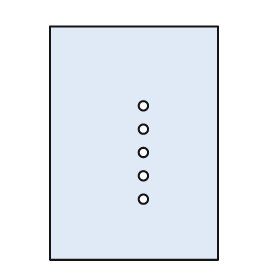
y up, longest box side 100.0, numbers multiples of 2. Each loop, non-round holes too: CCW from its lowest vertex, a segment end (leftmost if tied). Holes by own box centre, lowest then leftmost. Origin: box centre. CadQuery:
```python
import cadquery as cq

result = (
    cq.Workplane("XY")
    .moveTo(-36.0, -50.0)
    .lineTo(36.0, -50.0)
    .lineTo(36.0, 50.0)
    .lineTo(-36.0, 50.0)
    .close()
    .moveTo(4.0, -24.0)
    .circle(2.0)
    .moveTo(4.0, -14.0)
    .circle(2.0)
    .moveTo(4.0, -4.0)
    .circle(2.0)
    .moveTo(4.0, 6.0)
    .circle(2.0)
    .moveTo(4.0, 16.0)
    .circle(2.0)
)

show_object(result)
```